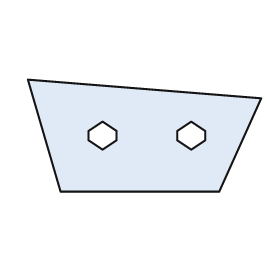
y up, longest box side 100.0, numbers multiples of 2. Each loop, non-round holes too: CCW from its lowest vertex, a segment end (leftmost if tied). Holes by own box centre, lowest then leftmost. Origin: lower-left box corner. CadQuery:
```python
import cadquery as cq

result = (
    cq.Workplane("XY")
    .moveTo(14.0, 0.0)
    .lineTo(82.0, 0.0)
    .lineTo(100.0, 40.0)
    .lineTo(0.0, 48.0)
    .close()
    .moveTo(32.0, 18.0)
    .lineTo(38.0, 22.0)
    .lineTo(38.0, 26.0)
    .lineTo(32.0, 30.0)
    .lineTo(26.0, 26.0)
    .lineTo(26.0, 22.0)
    .close()
    .moveTo(70.0, 18.0)
    .lineTo(76.0, 22.0)
    .lineTo(76.0, 26.0)
    .lineTo(70.0, 30.0)
    .lineTo(64.0, 26.0)
    .lineTo(64.0, 22.0)
    .close()
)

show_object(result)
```